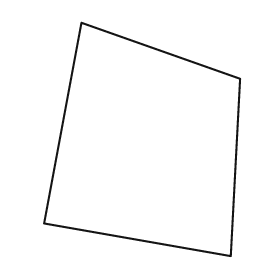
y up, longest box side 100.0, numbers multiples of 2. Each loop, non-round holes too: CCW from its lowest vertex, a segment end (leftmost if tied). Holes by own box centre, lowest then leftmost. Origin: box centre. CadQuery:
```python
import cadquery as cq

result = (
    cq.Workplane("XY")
    .moveTo(38.0, -50.0)
    .lineTo(42.0, 26.0)
    .lineTo(-26.0, 50.0)
    .lineTo(-42.0, -36.0)
    .close()
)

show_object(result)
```